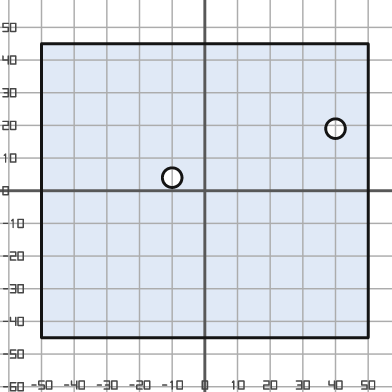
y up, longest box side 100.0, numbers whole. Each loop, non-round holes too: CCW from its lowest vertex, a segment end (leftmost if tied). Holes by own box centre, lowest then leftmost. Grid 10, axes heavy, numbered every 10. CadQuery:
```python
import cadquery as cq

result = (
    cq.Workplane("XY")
    .moveTo(-50.0, -45.0)
    .lineTo(50.0, -45.0)
    .lineTo(50.0, 45.0)
    .lineTo(-50.0, 45.0)
    .close()
    .moveTo(-10.0, 4.0)
    .circle(3.0)
    .moveTo(40.0, 19.0)
    .circle(3.0)
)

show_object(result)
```